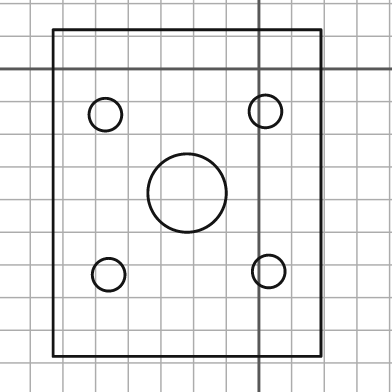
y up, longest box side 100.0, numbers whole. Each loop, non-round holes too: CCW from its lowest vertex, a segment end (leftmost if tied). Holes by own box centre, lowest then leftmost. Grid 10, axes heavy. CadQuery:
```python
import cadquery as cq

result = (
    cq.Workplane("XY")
    .moveTo(-63.0, -88.0)
    .lineTo(19.0, -88.0)
    .lineTo(19.0, 12.0)
    .lineTo(-63.0, 12.0)
    .close()
    .moveTo(-46.0, -63.0)
    .circle(5.0)
    .moveTo(3.0, -62.0)
    .circle(5.0)
    .moveTo(-22.0, -38.0)
    .circle(12.0)
    .moveTo(-47.0, -14.0)
    .circle(5.0)
    .moveTo(2.0, -13.0)
    .circle(5.0)
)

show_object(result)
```